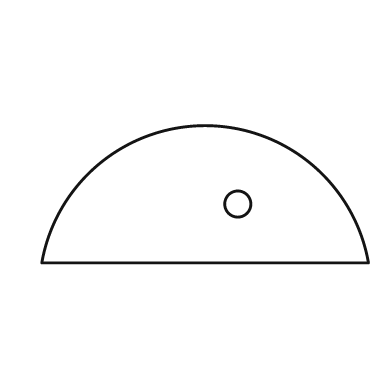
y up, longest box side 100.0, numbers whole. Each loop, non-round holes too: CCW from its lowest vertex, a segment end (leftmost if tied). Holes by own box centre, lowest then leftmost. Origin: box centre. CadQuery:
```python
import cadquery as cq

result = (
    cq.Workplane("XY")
    .moveTo(-50.0, -21.0)
    .lineTo(50.0, -21.0)
    .threePointArc((0.0, 21.0), (-50.0, -21.0))
    .close()
    .moveTo(10.0, -3.0)
    .circle(4.0)
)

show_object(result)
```